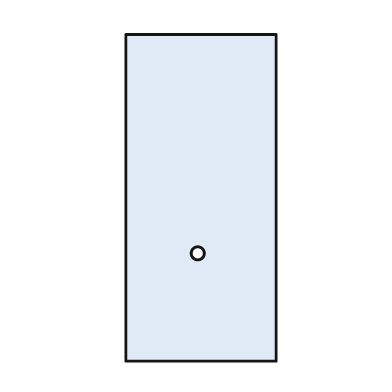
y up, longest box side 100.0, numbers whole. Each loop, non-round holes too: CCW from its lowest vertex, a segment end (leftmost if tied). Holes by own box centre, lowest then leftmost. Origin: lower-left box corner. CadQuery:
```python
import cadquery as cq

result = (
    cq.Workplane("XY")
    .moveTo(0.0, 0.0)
    .lineTo(46.0, 0.0)
    .lineTo(46.0, 100.0)
    .lineTo(0.0, 100.0)
    .close()
    .moveTo(22.0, 33.0)
    .circle(2.0)
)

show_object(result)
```